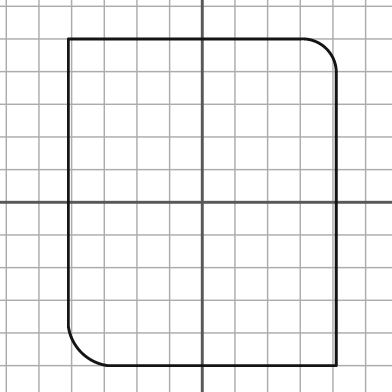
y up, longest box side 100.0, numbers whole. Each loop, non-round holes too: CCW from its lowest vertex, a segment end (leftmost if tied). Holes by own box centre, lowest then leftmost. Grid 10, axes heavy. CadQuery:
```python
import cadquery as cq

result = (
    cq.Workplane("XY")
    .moveTo(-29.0, -50.0)
    .lineTo(41.0, -50.0)
    .lineTo(41.0, 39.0)
    .threePointArc((38.0, 47.0), (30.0, 50.0))
    .lineTo(-41.0, 50.0)
    .lineTo(-41.0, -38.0)
    .threePointArc((-37.0, -46.0), (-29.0, -50.0))
    .close()
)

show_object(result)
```